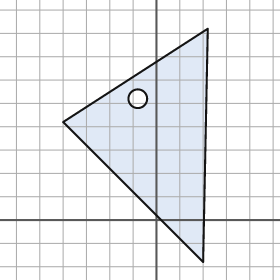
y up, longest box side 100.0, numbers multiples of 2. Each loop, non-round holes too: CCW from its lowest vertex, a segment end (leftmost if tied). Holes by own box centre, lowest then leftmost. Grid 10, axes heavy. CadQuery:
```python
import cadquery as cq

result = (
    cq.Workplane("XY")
    .moveTo(20.0, -18.0)
    .lineTo(22.0, 82.0)
    .lineTo(-40.0, 42.0)
    .close()
    .moveTo(-8.0, 52.0)
    .circle(4.0)
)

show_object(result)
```